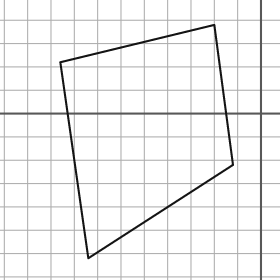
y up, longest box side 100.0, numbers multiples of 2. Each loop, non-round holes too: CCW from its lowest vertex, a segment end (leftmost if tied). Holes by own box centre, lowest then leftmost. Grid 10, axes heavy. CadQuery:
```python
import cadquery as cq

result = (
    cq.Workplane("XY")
    .moveTo(-74.0, -62.0)
    .lineTo(-12.0, -22.0)
    .lineTo(-20.0, 38.0)
    .lineTo(-86.0, 22.0)
    .close()
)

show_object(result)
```